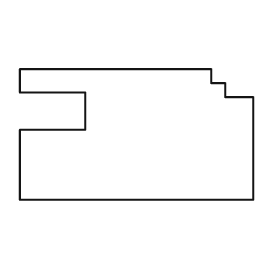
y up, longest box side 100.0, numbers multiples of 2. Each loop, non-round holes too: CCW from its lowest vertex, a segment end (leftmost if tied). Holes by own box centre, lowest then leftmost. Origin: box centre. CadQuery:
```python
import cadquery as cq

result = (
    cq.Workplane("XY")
    .moveTo(-50.0, -28.0)
    .lineTo(50.0, -28.0)
    .lineTo(50.0, 16.0)
    .lineTo(38.0, 16.0)
    .lineTo(38.0, 22.0)
    .lineTo(32.0, 22.0)
    .lineTo(32.0, 28.0)
    .lineTo(-50.0, 28.0)
    .lineTo(-50.0, 18.0)
    .lineTo(-22.0, 18.0)
    .lineTo(-22.0, 2.0)
    .lineTo(-50.0, 2.0)
    .close()
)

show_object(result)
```